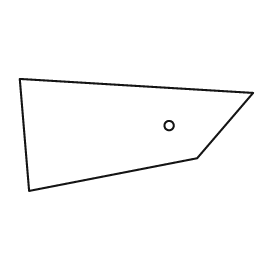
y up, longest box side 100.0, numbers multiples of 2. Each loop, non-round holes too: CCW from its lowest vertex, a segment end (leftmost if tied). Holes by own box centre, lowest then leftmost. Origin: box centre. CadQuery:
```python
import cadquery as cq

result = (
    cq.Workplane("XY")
    .moveTo(-46.0, -24.0)
    .lineTo(26.0, -10.0)
    .lineTo(50.0, 18.0)
    .lineTo(-50.0, 24.0)
    .close()
    .moveTo(14.0, 4.0)
    .circle(2.0)
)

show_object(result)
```